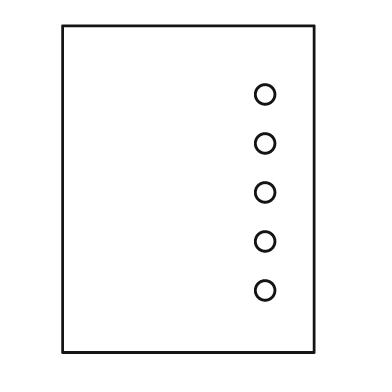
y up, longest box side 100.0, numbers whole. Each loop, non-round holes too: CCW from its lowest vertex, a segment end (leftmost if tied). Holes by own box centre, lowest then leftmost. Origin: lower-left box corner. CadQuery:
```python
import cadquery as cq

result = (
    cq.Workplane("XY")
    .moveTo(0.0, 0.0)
    .lineTo(77.0, 0.0)
    .lineTo(77.0, 100.0)
    .lineTo(0.0, 100.0)
    .close()
    .moveTo(62.0, 19.0)
    .circle(3.0)
    .moveTo(62.0, 34.0)
    .circle(3.0)
    .moveTo(62.0, 49.0)
    .circle(3.0)
    .moveTo(62.0, 64.0)
    .circle(3.0)
    .moveTo(62.0, 79.0)
    .circle(3.0)
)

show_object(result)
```